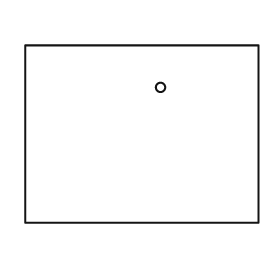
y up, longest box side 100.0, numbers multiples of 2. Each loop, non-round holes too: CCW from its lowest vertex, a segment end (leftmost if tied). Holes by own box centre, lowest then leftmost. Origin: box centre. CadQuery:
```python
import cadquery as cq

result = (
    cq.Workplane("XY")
    .moveTo(-50.0, -38.0)
    .lineTo(50.0, -38.0)
    .lineTo(50.0, 38.0)
    .lineTo(-50.0, 38.0)
    .close()
    .moveTo(8.0, 20.0)
    .circle(2.0)
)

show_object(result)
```